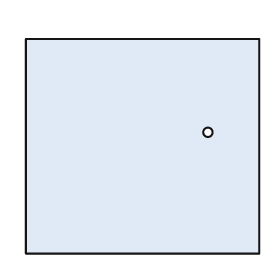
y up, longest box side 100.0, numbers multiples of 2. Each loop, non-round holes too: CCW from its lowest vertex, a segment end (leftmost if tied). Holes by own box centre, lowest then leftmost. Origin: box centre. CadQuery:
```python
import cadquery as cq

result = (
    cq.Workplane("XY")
    .moveTo(-50.0, -46.0)
    .lineTo(50.0, -46.0)
    .lineTo(50.0, 46.0)
    .lineTo(-50.0, 46.0)
    .close()
    .moveTo(28.0, 6.0)
    .circle(2.0)
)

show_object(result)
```